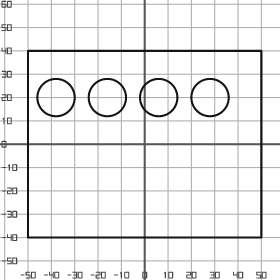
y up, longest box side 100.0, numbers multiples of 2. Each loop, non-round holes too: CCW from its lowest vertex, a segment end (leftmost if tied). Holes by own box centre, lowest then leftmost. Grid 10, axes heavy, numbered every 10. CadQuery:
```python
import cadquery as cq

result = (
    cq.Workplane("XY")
    .moveTo(-50.0, -40.0)
    .lineTo(50.0, -40.0)
    .lineTo(50.0, 40.0)
    .lineTo(-50.0, 40.0)
    .close()
    .moveTo(-38.0, 20.0)
    .circle(8.0)
    .moveTo(-16.0, 20.0)
    .circle(8.0)
    .moveTo(6.0, 20.0)
    .circle(8.0)
    .moveTo(28.0, 20.0)
    .circle(8.0)
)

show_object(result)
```